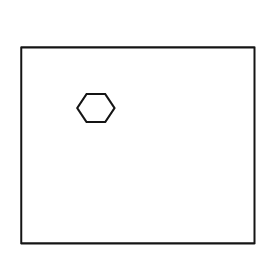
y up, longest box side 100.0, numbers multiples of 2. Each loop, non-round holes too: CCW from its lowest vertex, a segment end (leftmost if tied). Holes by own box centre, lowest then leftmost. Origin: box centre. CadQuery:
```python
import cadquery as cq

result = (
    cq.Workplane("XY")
    .moveTo(-50.0, -42.0)
    .lineTo(50.0, -42.0)
    .lineTo(50.0, 42.0)
    .lineTo(-50.0, 42.0)
    .close()
    .moveTo(-22.0, 10.0)
    .lineTo(-14.0, 10.0)
    .lineTo(-10.0, 16.0)
    .lineTo(-14.0, 22.0)
    .lineTo(-22.0, 22.0)
    .lineTo(-26.0, 16.0)
    .close()
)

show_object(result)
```